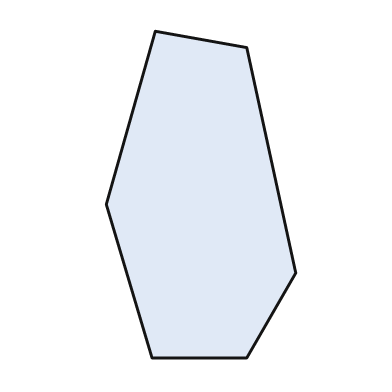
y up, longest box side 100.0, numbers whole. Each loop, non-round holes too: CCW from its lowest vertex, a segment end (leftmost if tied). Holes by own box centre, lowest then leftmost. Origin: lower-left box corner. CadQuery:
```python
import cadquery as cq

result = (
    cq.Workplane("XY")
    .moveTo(14.0, 0.0)
    .lineTo(43.0, 0.0)
    .lineTo(58.0, 26.0)
    .lineTo(43.0, 95.0)
    .lineTo(15.0, 100.0)
    .lineTo(0.0, 47.0)
    .close()
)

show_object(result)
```